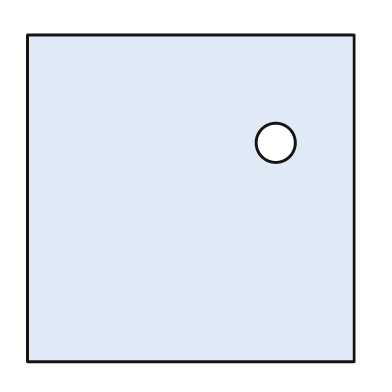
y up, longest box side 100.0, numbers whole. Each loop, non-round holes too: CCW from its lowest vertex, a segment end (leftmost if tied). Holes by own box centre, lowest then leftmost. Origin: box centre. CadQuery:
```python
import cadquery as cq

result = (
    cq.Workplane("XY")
    .moveTo(-50.0, -50.0)
    .lineTo(50.0, -50.0)
    .lineTo(50.0, 50.0)
    .lineTo(-50.0, 50.0)
    .close()
    .moveTo(26.0, 17.0)
    .circle(6.0)
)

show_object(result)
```